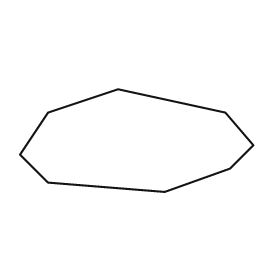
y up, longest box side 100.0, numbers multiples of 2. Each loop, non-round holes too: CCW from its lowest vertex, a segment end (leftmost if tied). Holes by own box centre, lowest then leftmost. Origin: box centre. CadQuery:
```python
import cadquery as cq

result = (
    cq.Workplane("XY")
    .moveTo(12.0, -22.0)
    .lineTo(40.0, -12.0)
    .lineTo(50.0, -2.0)
    .lineTo(38.0, 12.0)
    .lineTo(-8.0, 22.0)
    .lineTo(-38.0, 12.0)
    .lineTo(-50.0, -6.0)
    .lineTo(-38.0, -18.0)
    .close()
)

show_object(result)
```